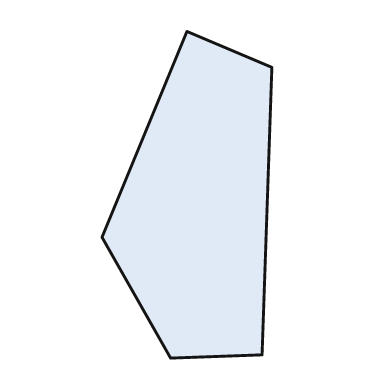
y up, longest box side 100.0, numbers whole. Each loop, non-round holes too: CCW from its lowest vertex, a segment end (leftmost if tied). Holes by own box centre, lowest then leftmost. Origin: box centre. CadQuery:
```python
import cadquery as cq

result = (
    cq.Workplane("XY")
    .moveTo(-5.0, -50.0)
    .lineTo(23.0, -49.0)
    .lineTo(26.0, 39.0)
    .lineTo(0.0, 50.0)
    .lineTo(-26.0, -13.0)
    .close()
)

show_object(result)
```